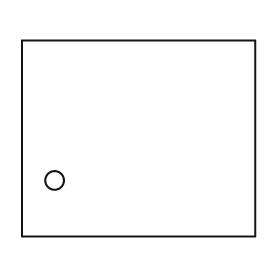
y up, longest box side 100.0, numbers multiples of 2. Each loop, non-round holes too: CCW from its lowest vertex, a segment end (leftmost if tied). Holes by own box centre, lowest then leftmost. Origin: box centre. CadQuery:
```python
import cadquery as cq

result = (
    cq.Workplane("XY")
    .moveTo(-50.0, -42.0)
    .lineTo(50.0, -42.0)
    .lineTo(50.0, 42.0)
    .lineTo(-50.0, 42.0)
    .close()
    .moveTo(-36.0, -18.0)
    .circle(4.0)
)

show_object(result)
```